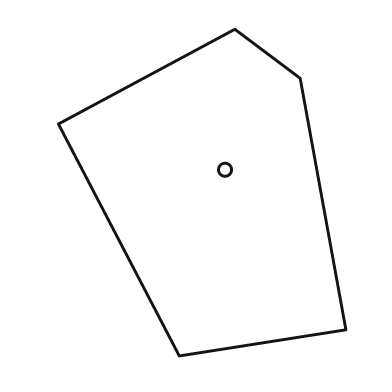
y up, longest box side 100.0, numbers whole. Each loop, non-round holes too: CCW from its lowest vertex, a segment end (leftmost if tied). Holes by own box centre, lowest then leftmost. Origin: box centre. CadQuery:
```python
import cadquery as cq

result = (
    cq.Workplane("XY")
    .moveTo(-7.0, -50.0)
    .lineTo(44.0, -42.0)
    .lineTo(30.0, 35.0)
    .lineTo(10.0, 50.0)
    .lineTo(-44.0, 21.0)
    .close()
    .moveTo(7.0, 7.0)
    .circle(2.0)
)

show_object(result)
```